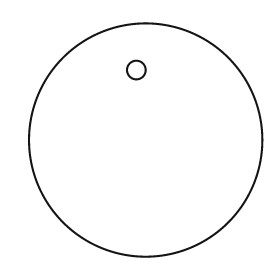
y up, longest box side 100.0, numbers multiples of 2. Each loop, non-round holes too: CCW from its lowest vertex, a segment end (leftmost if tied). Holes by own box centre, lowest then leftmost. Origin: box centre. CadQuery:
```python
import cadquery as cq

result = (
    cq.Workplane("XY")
    .moveTo(0.0, 0.0)
    .circle(50.0)
    .moveTo(-4.0, 30.0)
    .circle(4.0)
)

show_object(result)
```